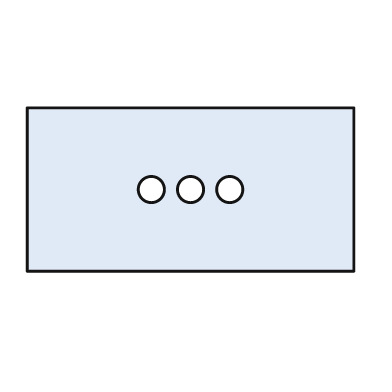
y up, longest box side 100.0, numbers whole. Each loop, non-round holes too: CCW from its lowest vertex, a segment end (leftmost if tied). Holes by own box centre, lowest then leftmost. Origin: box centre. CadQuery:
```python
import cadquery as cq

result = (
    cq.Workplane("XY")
    .moveTo(-50.0, -25.0)
    .lineTo(50.0, -25.0)
    .lineTo(50.0, 25.0)
    .lineTo(-50.0, 25.0)
    .close()
    .moveTo(-12.0, 0.0)
    .circle(4.0)
    .moveTo(0.0, 0.0)
    .circle(4.0)
    .moveTo(12.0, 0.0)
    .circle(4.0)
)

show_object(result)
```